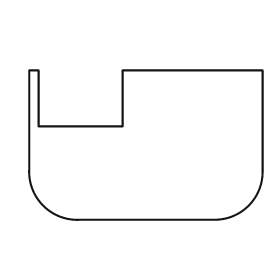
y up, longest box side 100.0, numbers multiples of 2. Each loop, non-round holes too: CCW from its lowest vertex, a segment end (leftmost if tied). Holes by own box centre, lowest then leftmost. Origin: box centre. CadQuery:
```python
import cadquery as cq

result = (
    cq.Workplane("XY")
    .moveTo(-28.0, -32.0)
    .lineTo(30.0, -32.0)
    .threePointArc((44.0, -26.0), (50.0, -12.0))
    .lineTo(50.0, 32.0)
    .lineTo(-10.0, 32.0)
    .lineTo(-10.0, 8.0)
    .lineTo(-46.0, 8.0)
    .lineTo(-46.0, 32.0)
    .lineTo(-50.0, 32.0)
    .lineTo(-50.0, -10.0)
    .threePointArc((-44.0, -26.0), (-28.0, -32.0))
    .close()
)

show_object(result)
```